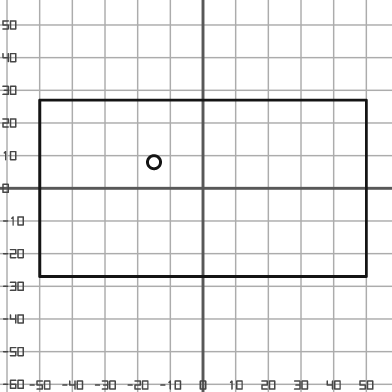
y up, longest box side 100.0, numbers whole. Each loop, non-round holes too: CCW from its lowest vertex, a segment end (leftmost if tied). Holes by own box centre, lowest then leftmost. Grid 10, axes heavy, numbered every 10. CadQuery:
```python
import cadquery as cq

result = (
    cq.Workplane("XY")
    .moveTo(-50.0, -27.0)
    .lineTo(50.0, -27.0)
    .lineTo(50.0, 27.0)
    .lineTo(-50.0, 27.0)
    .close()
    .moveTo(-15.0, 8.0)
    .circle(2.0)
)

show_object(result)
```